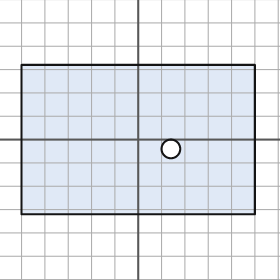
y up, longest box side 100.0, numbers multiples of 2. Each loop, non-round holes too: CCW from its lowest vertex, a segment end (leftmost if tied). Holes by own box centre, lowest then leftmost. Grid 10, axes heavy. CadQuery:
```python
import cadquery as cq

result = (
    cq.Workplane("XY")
    .moveTo(-50.0, -32.0)
    .lineTo(50.0, -32.0)
    .lineTo(50.0, 32.0)
    .lineTo(-50.0, 32.0)
    .close()
    .moveTo(14.0, -4.0)
    .circle(4.0)
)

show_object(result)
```